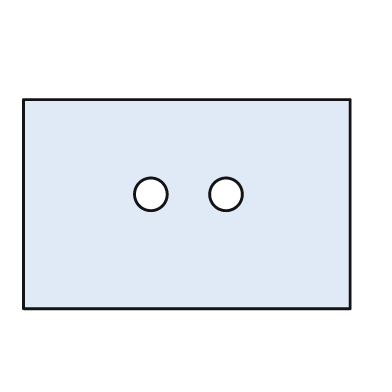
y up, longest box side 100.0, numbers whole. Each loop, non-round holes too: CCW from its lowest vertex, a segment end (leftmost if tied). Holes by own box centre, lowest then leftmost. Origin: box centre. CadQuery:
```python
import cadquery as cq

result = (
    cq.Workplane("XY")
    .moveTo(-50.0, -32.0)
    .lineTo(50.0, -32.0)
    .lineTo(50.0, 32.0)
    .lineTo(-50.0, 32.0)
    .close()
    .moveTo(-11.0, 3.0)
    .circle(5.0)
    .moveTo(12.0, 3.0)
    .circle(5.0)
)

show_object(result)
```